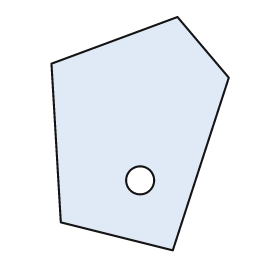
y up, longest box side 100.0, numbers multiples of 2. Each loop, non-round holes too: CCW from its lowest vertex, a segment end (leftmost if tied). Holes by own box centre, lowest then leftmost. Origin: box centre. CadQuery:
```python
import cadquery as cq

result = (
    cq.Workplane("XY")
    .moveTo(14.0, -50.0)
    .lineTo(38.0, 24.0)
    .lineTo(16.0, 50.0)
    .lineTo(-38.0, 30.0)
    .lineTo(-34.0, -38.0)
    .close()
    .moveTo(0.0, -20.0)
    .circle(6.0)
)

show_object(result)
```